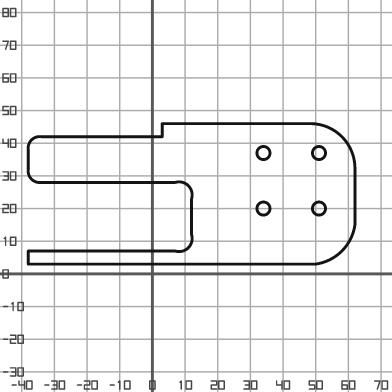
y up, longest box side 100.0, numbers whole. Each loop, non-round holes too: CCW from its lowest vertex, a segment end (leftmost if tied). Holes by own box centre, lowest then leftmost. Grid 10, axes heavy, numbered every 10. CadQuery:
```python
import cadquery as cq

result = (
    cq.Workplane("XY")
    .moveTo(-38.0, 3.0)
    .lineTo(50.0, 3.0)
    .threePointArc((58.0, 7.0), (62.0, 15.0))
    .lineTo(62.0, 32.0)
    .threePointArc((58.0, 42.0), (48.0, 46.0))
    .lineTo(3.0, 46.0)
    .lineTo(3.0, 42.0)
    .lineTo(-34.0, 42.0)
    .threePointArc((-37.0, 41.0), (-38.0, 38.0))
    .lineTo(-38.0, 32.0)
    .threePointArc((-37.0, 29.0), (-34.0, 28.0))
    .lineTo(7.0, 28.0)
    .threePointArc((11.0, 27.0), (12.0, 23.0))
    .lineTo(12.0, 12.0)
    .threePointArc((11.0, 8.0), (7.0, 7.0))
    .lineTo(-38.0, 7.0)
    .close()
    .moveTo(34.0, 20.0)
    .circle(2.0)
    .moveTo(51.0, 20.0)
    .circle(2.0)
    .moveTo(34.0, 37.0)
    .circle(2.0)
    .moveTo(51.0, 37.0)
    .circle(2.0)
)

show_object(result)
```